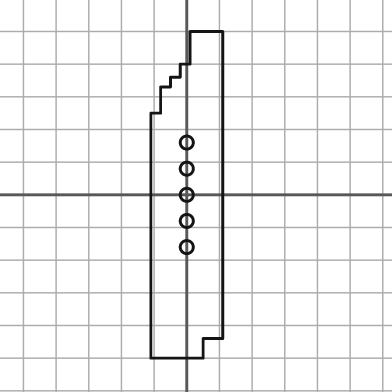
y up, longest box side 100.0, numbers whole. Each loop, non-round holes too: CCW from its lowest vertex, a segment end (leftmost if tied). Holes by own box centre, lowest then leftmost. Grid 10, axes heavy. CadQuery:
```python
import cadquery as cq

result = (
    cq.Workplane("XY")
    .moveTo(-11.0, -50.0)
    .lineTo(5.0, -50.0)
    .lineTo(5.0, -44.0)
    .lineTo(11.0, -44.0)
    .lineTo(11.0, 50.0)
    .lineTo(1.0, 50.0)
    .lineTo(1.0, 40.0)
    .lineTo(-2.0, 40.0)
    .lineTo(-2.0, 36.0)
    .lineTo(-5.0, 36.0)
    .lineTo(-5.0, 33.0)
    .lineTo(-8.0, 33.0)
    .lineTo(-8.0, 25.0)
    .lineTo(-11.0, 25.0)
    .close()
    .moveTo(0.0, -16.0)
    .circle(2.0)
    .moveTo(0.0, -8.0)
    .circle(2.0)
    .moveTo(0.0, 0.0)
    .circle(2.0)
    .moveTo(0.0, 8.0)
    .circle(2.0)
    .moveTo(0.0, 16.0)
    .circle(2.0)
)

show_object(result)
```